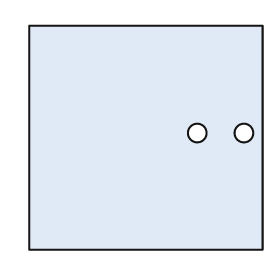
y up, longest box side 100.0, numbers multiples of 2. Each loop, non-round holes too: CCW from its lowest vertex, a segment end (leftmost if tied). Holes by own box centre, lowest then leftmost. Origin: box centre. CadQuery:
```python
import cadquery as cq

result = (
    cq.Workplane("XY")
    .moveTo(-50.0, -48.0)
    .lineTo(50.0, -48.0)
    .lineTo(50.0, 48.0)
    .lineTo(-50.0, 48.0)
    .close()
    .moveTo(22.0, 2.0)
    .circle(4.0)
    .moveTo(42.0, 2.0)
    .circle(4.0)
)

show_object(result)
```